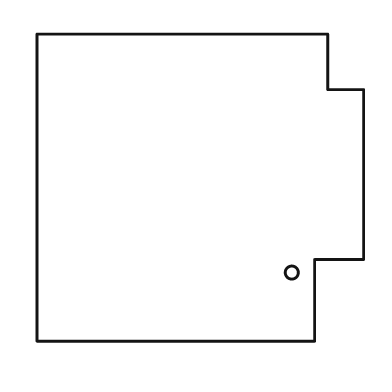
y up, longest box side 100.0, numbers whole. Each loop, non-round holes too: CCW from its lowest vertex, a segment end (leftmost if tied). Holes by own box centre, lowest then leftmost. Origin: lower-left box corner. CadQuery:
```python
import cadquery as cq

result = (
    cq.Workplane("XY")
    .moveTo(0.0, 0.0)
    .lineTo(85.0, 0.0)
    .lineTo(85.0, 25.0)
    .lineTo(100.0, 25.0)
    .lineTo(100.0, 77.0)
    .lineTo(89.0, 77.0)
    .lineTo(89.0, 94.0)
    .lineTo(0.0, 94.0)
    .close()
    .moveTo(78.0, 21.0)
    .circle(2.0)
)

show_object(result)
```